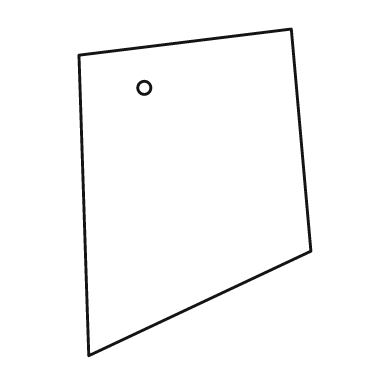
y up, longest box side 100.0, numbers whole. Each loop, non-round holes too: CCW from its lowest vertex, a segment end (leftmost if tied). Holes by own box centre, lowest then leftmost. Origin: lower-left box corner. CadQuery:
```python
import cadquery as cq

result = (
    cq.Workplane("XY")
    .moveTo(3.0, 0.0)
    .lineTo(71.0, 32.0)
    .lineTo(65.0, 100.0)
    .lineTo(0.0, 92.0)
    .close()
    .moveTo(20.0, 82.0)
    .circle(2.0)
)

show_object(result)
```